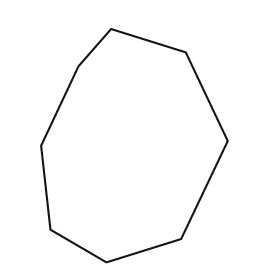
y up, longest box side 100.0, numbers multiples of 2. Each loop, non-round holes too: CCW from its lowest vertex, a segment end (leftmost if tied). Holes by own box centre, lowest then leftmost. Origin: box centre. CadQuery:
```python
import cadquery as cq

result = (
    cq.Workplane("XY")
    .moveTo(-12.0, -50.0)
    .lineTo(20.0, -40.0)
    .lineTo(40.0, 2.0)
    .lineTo(22.0, 40.0)
    .lineTo(-10.0, 50.0)
    .lineTo(-24.0, 34.0)
    .lineTo(-40.0, 0.0)
    .lineTo(-36.0, -36.0)
    .close()
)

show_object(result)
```